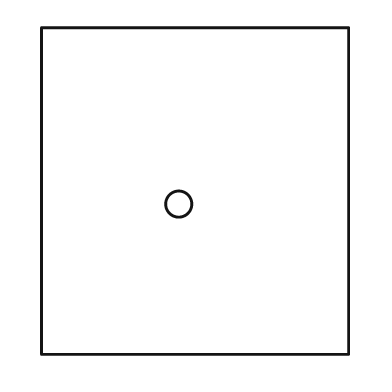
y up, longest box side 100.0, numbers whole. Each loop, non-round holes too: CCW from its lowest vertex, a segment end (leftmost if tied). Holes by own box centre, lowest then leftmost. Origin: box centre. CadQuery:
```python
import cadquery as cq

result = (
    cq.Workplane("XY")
    .moveTo(-47.0, -50.0)
    .lineTo(47.0, -50.0)
    .lineTo(47.0, 50.0)
    .lineTo(-47.0, 50.0)
    .close()
    .moveTo(-5.0, -4.0)
    .circle(4.0)
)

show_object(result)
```